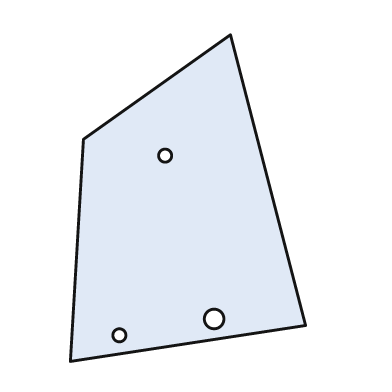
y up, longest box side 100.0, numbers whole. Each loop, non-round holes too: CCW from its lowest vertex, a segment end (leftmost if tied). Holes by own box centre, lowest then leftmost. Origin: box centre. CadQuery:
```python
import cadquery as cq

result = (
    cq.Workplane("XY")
    .moveTo(-36.0, -50.0)
    .lineTo(36.0, -39.0)
    .lineTo(13.0, 50.0)
    .lineTo(-32.0, 18.0)
    .close()
    .moveTo(-21.0, -42.0)
    .circle(2.0)
    .moveTo(8.0, -37.0)
    .circle(3.0)
    .moveTo(-7.0, 13.0)
    .circle(2.0)
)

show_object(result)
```